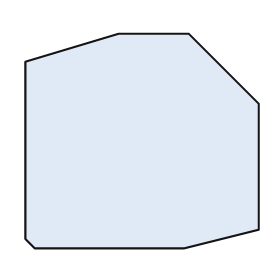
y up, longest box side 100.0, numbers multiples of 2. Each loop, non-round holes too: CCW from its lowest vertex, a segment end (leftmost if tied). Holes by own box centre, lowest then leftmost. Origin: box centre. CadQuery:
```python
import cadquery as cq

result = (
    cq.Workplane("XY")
    .moveTo(-46.0, -46.0)
    .lineTo(18.0, -46.0)
    .lineTo(50.0, -38.0)
    .lineTo(50.0, 16.0)
    .lineTo(20.0, 46.0)
    .lineTo(-10.0, 46.0)
    .lineTo(-50.0, 34.0)
    .lineTo(-50.0, -42.0)
    .close()
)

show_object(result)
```